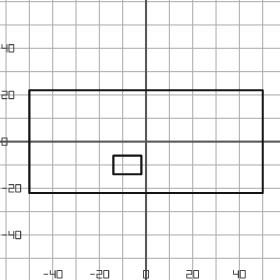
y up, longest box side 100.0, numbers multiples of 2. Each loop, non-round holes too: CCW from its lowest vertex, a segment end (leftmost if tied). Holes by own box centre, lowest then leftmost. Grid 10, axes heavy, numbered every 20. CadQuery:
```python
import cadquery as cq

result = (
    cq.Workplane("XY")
    .moveTo(-50.0, -22.0)
    .lineTo(50.0, -22.0)
    .lineTo(50.0, 22.0)
    .lineTo(-50.0, 22.0)
    .close()
    .moveTo(-14.0, -14.0)
    .lineTo(-2.0, -14.0)
    .lineTo(-2.0, -6.0)
    .lineTo(-14.0, -6.0)
    .close()
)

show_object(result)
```